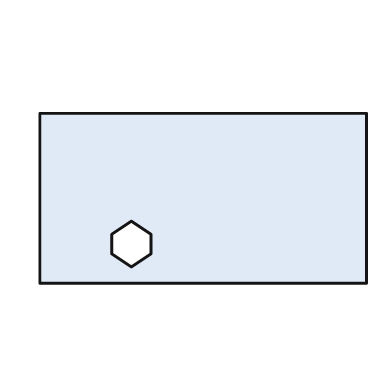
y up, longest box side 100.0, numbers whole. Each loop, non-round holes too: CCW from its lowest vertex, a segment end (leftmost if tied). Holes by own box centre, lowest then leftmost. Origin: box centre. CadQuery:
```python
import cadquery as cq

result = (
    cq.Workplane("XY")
    .moveTo(-50.0, -26.0)
    .lineTo(50.0, -26.0)
    .lineTo(50.0, 26.0)
    .lineTo(-50.0, 26.0)
    .close()
    .moveTo(-22.0, -21.0)
    .lineTo(-16.0, -17.0)
    .lineTo(-16.0, -11.0)
    .lineTo(-22.0, -7.0)
    .lineTo(-28.0, -11.0)
    .lineTo(-28.0, -17.0)
    .close()
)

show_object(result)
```